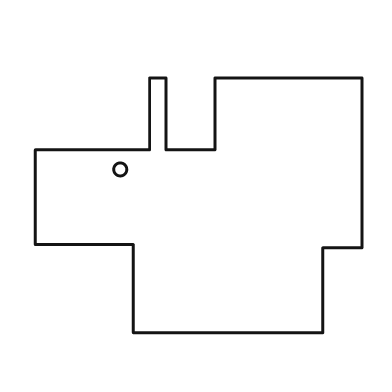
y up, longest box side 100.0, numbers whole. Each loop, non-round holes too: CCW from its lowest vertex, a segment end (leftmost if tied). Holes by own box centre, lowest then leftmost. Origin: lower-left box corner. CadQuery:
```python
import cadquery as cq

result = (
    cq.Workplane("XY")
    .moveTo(30.0, 0.0)
    .lineTo(88.0, 0.0)
    .lineTo(88.0, 26.0)
    .lineTo(100.0, 26.0)
    .lineTo(100.0, 78.0)
    .lineTo(55.0, 78.0)
    .lineTo(55.0, 56.0)
    .lineTo(40.0, 56.0)
    .lineTo(40.0, 78.0)
    .lineTo(35.0, 78.0)
    .lineTo(35.0, 56.0)
    .lineTo(0.0, 56.0)
    .lineTo(0.0, 27.0)
    .lineTo(30.0, 27.0)
    .close()
    .moveTo(26.0, 50.0)
    .circle(2.0)
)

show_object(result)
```